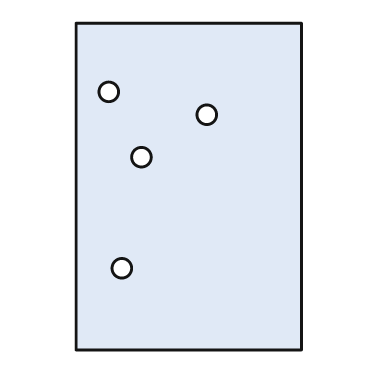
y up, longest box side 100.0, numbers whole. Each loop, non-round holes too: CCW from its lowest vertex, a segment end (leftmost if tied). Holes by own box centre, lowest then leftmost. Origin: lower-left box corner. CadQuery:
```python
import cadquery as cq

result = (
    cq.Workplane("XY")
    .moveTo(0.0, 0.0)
    .lineTo(69.0, 0.0)
    .lineTo(69.0, 100.0)
    .lineTo(0.0, 100.0)
    .close()
    .moveTo(14.0, 25.0)
    .circle(3.0)
    .moveTo(20.0, 59.0)
    .circle(3.0)
    .moveTo(40.0, 72.0)
    .circle(3.0)
    .moveTo(10.0, 79.0)
    .circle(3.0)
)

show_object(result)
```